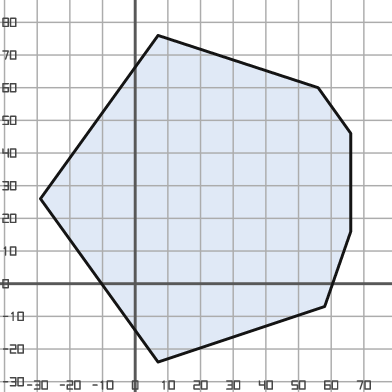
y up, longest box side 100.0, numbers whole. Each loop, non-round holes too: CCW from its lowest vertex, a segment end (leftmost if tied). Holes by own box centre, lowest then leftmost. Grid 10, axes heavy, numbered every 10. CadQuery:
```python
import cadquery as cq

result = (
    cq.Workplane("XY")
    .moveTo(7.0, -24.0)
    .lineTo(58.0, -7.0)
    .lineTo(66.0, 16.0)
    .lineTo(66.0, 46.0)
    .lineTo(56.0, 60.0)
    .lineTo(7.0, 76.0)
    .lineTo(-29.0, 26.0)
    .close()
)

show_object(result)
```